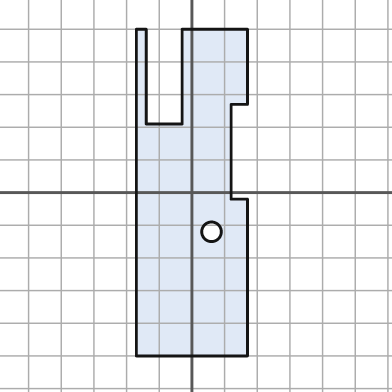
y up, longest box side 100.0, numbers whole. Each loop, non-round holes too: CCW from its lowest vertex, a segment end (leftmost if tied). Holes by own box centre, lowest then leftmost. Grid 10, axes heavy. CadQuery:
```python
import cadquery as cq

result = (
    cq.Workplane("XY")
    .moveTo(-17.0, -50.0)
    .lineTo(17.0, -50.0)
    .lineTo(17.0, -2.0)
    .lineTo(12.0, -2.0)
    .lineTo(12.0, 27.0)
    .lineTo(17.0, 27.0)
    .lineTo(17.0, 50.0)
    .lineTo(-3.0, 50.0)
    .lineTo(-3.0, 21.0)
    .lineTo(-14.0, 21.0)
    .lineTo(-14.0, 50.0)
    .lineTo(-17.0, 50.0)
    .close()
    .moveTo(6.0, -12.0)
    .circle(3.0)
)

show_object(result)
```